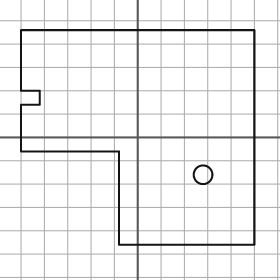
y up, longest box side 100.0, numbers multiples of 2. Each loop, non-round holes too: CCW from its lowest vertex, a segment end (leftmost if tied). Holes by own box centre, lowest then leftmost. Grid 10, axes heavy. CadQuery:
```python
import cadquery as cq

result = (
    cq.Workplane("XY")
    .moveTo(-8.0, -46.0)
    .lineTo(50.0, -46.0)
    .lineTo(50.0, 46.0)
    .lineTo(-50.0, 46.0)
    .lineTo(-50.0, 20.0)
    .lineTo(-42.0, 20.0)
    .lineTo(-42.0, 14.0)
    .lineTo(-50.0, 14.0)
    .lineTo(-50.0, -6.0)
    .lineTo(-8.0, -6.0)
    .close()
    .moveTo(28.0, -16.0)
    .circle(4.0)
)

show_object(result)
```